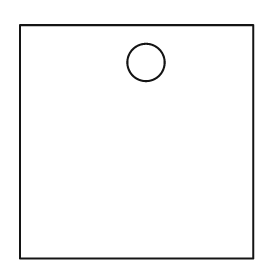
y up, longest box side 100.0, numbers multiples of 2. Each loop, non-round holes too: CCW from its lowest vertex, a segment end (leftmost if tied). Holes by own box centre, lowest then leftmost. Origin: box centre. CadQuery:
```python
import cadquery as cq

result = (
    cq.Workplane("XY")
    .moveTo(-50.0, -50.0)
    .lineTo(50.0, -50.0)
    .lineTo(50.0, 50.0)
    .lineTo(-50.0, 50.0)
    .close()
    .moveTo(4.0, 34.0)
    .circle(8.0)
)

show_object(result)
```